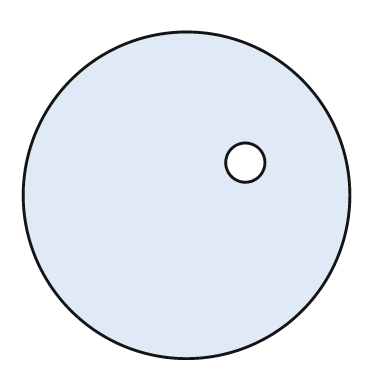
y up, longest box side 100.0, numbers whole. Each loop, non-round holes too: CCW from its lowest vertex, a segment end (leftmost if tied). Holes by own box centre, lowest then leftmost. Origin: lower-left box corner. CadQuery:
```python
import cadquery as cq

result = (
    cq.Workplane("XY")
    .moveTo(50.0, 50.0)
    .circle(50.0)
    .moveTo(68.0, 60.0)
    .circle(6.0)
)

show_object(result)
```